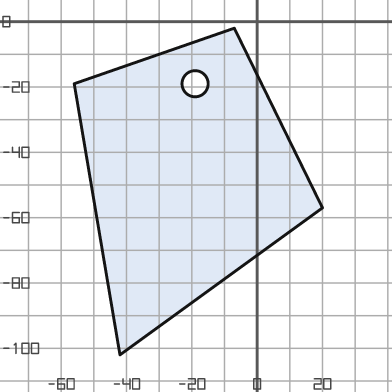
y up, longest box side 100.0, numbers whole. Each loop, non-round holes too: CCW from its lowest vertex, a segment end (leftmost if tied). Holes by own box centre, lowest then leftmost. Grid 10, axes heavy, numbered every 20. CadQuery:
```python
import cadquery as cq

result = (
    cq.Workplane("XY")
    .moveTo(-42.0, -102.0)
    .lineTo(20.0, -57.0)
    .lineTo(-7.0, -2.0)
    .lineTo(-56.0, -19.0)
    .close()
    .moveTo(-19.0, -19.0)
    .circle(4.0)
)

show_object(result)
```